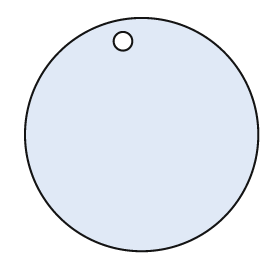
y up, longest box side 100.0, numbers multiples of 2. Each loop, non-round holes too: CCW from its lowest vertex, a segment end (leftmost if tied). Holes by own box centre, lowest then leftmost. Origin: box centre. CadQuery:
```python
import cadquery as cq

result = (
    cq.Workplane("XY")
    .moveTo(0.0, 0.0)
    .circle(50.0)
    .moveTo(-8.0, 40.0)
    .circle(4.0)
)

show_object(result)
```